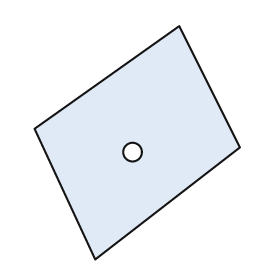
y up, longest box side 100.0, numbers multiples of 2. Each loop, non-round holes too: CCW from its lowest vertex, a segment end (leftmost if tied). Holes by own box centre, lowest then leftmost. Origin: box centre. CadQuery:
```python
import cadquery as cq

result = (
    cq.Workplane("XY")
    .moveTo(-18.0, -50.0)
    .lineTo(44.0, -2.0)
    .lineTo(18.0, 50.0)
    .lineTo(-44.0, 6.0)
    .close()
    .moveTo(-2.0, -4.0)
    .circle(4.0)
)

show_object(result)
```